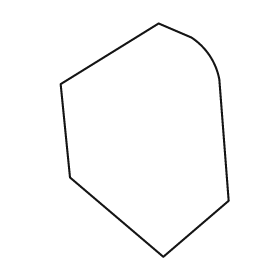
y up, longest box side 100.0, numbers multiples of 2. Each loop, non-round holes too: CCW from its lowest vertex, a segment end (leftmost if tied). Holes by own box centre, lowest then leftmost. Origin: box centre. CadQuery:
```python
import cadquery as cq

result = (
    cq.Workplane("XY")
    .moveTo(8.0, -50.0)
    .lineTo(36.0, -26.0)
    .lineTo(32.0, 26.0)
    .threePointArc((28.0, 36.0), (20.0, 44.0))
    .lineTo(6.0, 50.0)
    .lineTo(-36.0, 24.0)
    .lineTo(-32.0, -16.0)
    .close()
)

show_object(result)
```